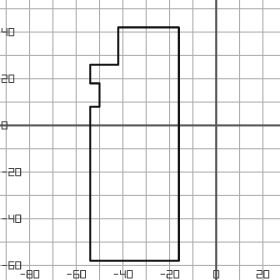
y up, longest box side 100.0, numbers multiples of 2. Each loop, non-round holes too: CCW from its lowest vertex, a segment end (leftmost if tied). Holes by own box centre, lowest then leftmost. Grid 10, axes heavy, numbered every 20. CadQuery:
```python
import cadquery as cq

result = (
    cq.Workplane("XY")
    .moveTo(-54.0, -58.0)
    .lineTo(-16.0, -58.0)
    .lineTo(-16.0, 42.0)
    .lineTo(-42.0, 42.0)
    .lineTo(-42.0, 26.0)
    .lineTo(-54.0, 26.0)
    .lineTo(-54.0, 18.0)
    .lineTo(-50.0, 18.0)
    .lineTo(-50.0, 8.0)
    .lineTo(-54.0, 8.0)
    .close()
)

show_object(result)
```